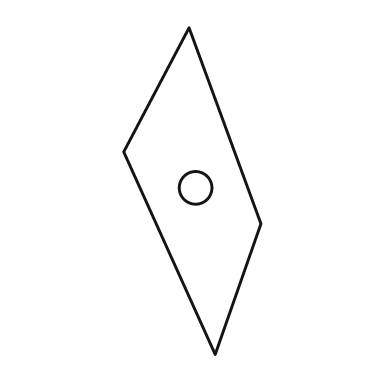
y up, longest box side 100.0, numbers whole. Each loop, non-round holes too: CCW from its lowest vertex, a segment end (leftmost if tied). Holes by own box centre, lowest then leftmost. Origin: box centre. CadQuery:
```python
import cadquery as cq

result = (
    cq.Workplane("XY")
    .moveTo(7.0, -50.0)
    .lineTo(21.0, -10.0)
    .lineTo(-1.0, 50.0)
    .lineTo(-21.0, 12.0)
    .close()
    .moveTo(1.0, 1.0)
    .circle(5.0)
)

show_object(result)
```